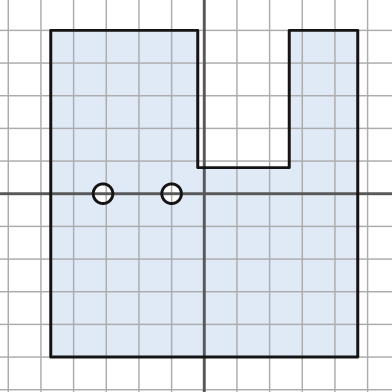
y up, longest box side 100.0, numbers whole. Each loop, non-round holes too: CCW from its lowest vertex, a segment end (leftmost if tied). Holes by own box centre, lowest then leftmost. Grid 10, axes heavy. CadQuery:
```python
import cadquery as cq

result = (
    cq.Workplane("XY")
    .moveTo(-47.0, -50.0)
    .lineTo(47.0, -50.0)
    .lineTo(47.0, 50.0)
    .lineTo(26.0, 50.0)
    .lineTo(26.0, 8.0)
    .lineTo(-2.0, 8.0)
    .lineTo(-2.0, 50.0)
    .lineTo(-47.0, 50.0)
    .close()
    .moveTo(-31.0, 0.0)
    .circle(3.0)
    .moveTo(-10.0, 0.0)
    .circle(3.0)
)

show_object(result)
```